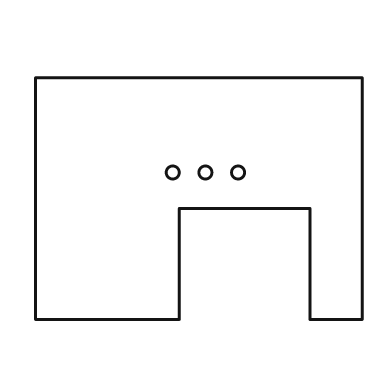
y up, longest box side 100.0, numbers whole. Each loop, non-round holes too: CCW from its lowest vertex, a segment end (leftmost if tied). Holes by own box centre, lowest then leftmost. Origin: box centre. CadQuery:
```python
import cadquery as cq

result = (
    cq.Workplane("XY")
    .moveTo(-50.0, -37.0)
    .lineTo(-6.0, -37.0)
    .lineTo(-6.0, -3.0)
    .lineTo(34.0, -3.0)
    .lineTo(34.0, -37.0)
    .lineTo(50.0, -37.0)
    .lineTo(50.0, 37.0)
    .lineTo(-50.0, 37.0)
    .close()
    .moveTo(-8.0, 8.0)
    .circle(2.0)
    .moveTo(2.0, 8.0)
    .circle(2.0)
    .moveTo(12.0, 8.0)
    .circle(2.0)
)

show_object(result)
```